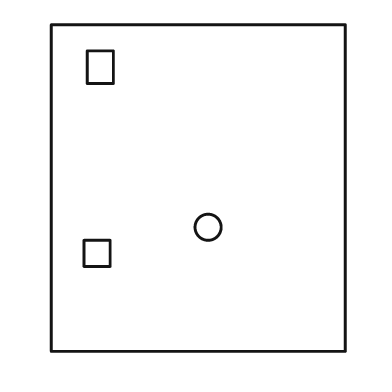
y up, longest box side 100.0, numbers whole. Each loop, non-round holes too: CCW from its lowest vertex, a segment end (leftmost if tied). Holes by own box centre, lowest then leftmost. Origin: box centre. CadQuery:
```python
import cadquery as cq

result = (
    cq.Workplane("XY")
    .moveTo(-45.0, -50.0)
    .lineTo(45.0, -50.0)
    .lineTo(45.0, 50.0)
    .lineTo(-45.0, 50.0)
    .close()
    .moveTo(-35.0, -24.0)
    .lineTo(-27.0, -24.0)
    .lineTo(-27.0, -16.0)
    .lineTo(-35.0, -16.0)
    .close()
    .moveTo(3.0, -12.0)
    .circle(4.0)
    .moveTo(-34.0, 32.0)
    .lineTo(-26.0, 32.0)
    .lineTo(-26.0, 42.0)
    .lineTo(-34.0, 42.0)
    .close()
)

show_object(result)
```